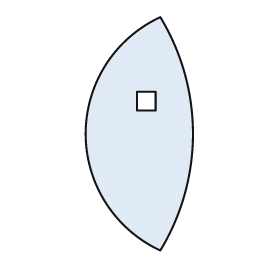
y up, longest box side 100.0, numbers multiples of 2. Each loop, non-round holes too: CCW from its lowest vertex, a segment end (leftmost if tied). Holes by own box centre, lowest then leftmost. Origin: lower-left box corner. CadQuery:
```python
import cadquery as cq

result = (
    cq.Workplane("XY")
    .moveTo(32.0, 0.0)
    .threePointArc((46.0, 50.0), (32.0, 100.0))
    .threePointArc((0.0, 50.0), (32.0, 0.0))
    .close()
    .moveTo(22.0, 60.0)
    .lineTo(30.0, 60.0)
    .lineTo(30.0, 68.0)
    .lineTo(22.0, 68.0)
    .close()
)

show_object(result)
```